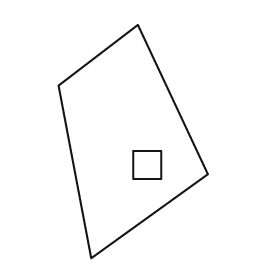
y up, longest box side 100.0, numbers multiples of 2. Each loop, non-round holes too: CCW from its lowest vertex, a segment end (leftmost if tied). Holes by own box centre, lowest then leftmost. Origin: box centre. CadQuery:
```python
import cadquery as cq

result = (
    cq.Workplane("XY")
    .moveTo(-18.0, -50.0)
    .lineTo(32.0, -14.0)
    .lineTo(2.0, 50.0)
    .lineTo(-32.0, 24.0)
    .close()
    .moveTo(0.0, -16.0)
    .lineTo(12.0, -16.0)
    .lineTo(12.0, -4.0)
    .lineTo(0.0, -4.0)
    .close()
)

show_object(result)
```